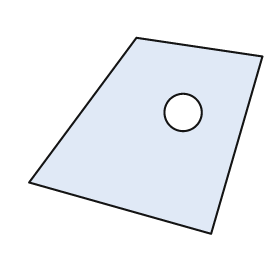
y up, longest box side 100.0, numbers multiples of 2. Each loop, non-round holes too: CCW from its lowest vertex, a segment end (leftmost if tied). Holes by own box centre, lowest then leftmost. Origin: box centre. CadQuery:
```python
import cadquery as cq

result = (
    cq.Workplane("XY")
    .moveTo(28.0, -42.0)
    .lineTo(50.0, 34.0)
    .lineTo(-4.0, 42.0)
    .lineTo(-50.0, -20.0)
    .close()
    .moveTo(16.0, 10.0)
    .circle(8.0)
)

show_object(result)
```